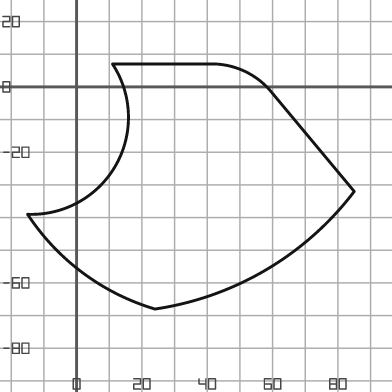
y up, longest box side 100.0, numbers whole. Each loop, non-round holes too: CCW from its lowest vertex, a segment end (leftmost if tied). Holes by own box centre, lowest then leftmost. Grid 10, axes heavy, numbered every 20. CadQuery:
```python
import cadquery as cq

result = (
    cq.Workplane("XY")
    .moveTo(24.0, -68.0)
    .threePointArc((58.0, -56.0), (85.0, -32.0))
    .lineTo(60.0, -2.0)
    .threePointArc((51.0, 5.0), (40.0, 7.0))
    .lineTo(11.0, 7.0)
    .threePointArc((12.0, -24.0), (-15.0, -39.0))
    .threePointArc((2.0, -57.0), (24.0, -68.0))
    .close()
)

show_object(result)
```